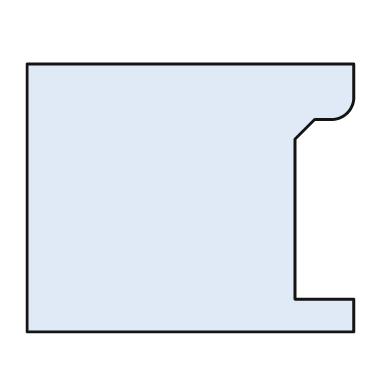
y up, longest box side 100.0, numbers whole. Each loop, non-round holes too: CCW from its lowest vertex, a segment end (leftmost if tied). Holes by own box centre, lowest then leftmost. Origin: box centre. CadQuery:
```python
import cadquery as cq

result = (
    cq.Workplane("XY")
    .moveTo(-50.0, -41.0)
    .lineTo(50.0, -41.0)
    .lineTo(50.0, -31.0)
    .lineTo(32.0, -31.0)
    .lineTo(32.0, 18.0)
    .lineTo(38.0, 24.0)
    .lineTo(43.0, 24.0)
    .threePointArc((48.0, 26.0), (50.0, 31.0))
    .lineTo(50.0, 41.0)
    .lineTo(-50.0, 41.0)
    .close()
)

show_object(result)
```